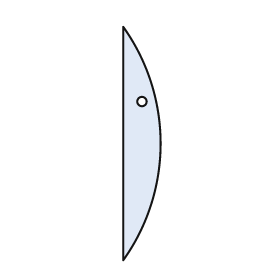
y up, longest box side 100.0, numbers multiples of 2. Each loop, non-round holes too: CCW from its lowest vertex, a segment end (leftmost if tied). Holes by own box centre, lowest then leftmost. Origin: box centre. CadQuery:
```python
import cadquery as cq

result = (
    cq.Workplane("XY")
    .moveTo(-8.0, -50.0)
    .threePointArc((8.0, 0.0), (-8.0, 50.0))
    .close()
    .moveTo(0.0, 18.0)
    .circle(2.0)
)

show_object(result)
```